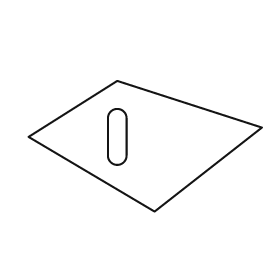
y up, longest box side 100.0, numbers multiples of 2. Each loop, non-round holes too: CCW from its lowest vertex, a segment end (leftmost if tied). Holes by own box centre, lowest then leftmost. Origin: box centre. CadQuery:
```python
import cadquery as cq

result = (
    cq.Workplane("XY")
    .moveTo(4.0, -28.0)
    .lineTo(50.0, 8.0)
    .lineTo(-12.0, 28.0)
    .lineTo(-50.0, 4.0)
    .close()
    .moveTo(-16.0, -4.0)
    .threePointArc((-12.0, -8.0), (-8.0, -4.0))
    .lineTo(-8.0, 12.0)
    .threePointArc((-12.0, 16.0), (-16.0, 12.0))
    .close()
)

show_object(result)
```